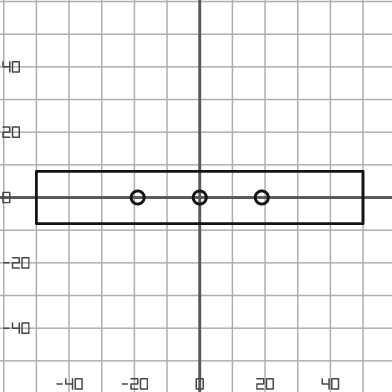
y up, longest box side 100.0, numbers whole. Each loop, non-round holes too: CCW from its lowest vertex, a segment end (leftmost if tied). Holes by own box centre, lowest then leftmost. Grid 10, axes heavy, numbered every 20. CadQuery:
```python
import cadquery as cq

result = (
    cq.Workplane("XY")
    .moveTo(-50.0, -8.0)
    .lineTo(50.0, -8.0)
    .lineTo(50.0, 8.0)
    .lineTo(-50.0, 8.0)
    .close()
    .moveTo(-19.0, 0.0)
    .circle(2.0)
    .moveTo(0.0, 0.0)
    .circle(2.0)
    .moveTo(19.0, 0.0)
    .circle(2.0)
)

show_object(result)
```